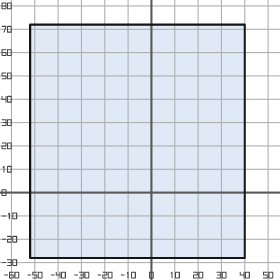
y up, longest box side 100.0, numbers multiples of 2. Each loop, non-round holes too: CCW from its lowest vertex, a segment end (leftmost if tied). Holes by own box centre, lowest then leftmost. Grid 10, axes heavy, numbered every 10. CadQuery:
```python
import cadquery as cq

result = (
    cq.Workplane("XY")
    .moveTo(-52.0, -28.0)
    .lineTo(40.0, -28.0)
    .lineTo(40.0, 72.0)
    .lineTo(-52.0, 72.0)
    .close()
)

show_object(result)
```